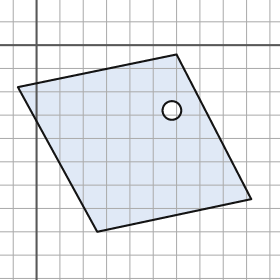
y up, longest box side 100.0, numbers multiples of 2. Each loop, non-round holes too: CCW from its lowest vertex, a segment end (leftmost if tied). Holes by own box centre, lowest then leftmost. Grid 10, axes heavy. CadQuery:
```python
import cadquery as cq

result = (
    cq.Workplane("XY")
    .moveTo(26.0, -80.0)
    .lineTo(92.0, -66.0)
    .lineTo(60.0, -4.0)
    .lineTo(-8.0, -18.0)
    .close()
    .moveTo(58.0, -28.0)
    .circle(4.0)
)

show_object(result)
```